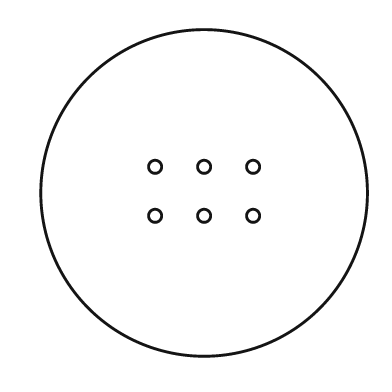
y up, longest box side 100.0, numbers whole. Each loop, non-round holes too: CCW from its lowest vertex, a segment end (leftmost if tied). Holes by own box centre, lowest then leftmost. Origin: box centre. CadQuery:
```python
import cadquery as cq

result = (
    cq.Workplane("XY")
    .moveTo(0.0, 0.0)
    .circle(50.0)
    .moveTo(-15.0, -7.0)
    .circle(2.0)
    .moveTo(0.0, -7.0)
    .circle(2.0)
    .moveTo(15.0, -7.0)
    .circle(2.0)
    .moveTo(-15.0, 8.0)
    .circle(2.0)
    .moveTo(0.0, 8.0)
    .circle(2.0)
    .moveTo(15.0, 8.0)
    .circle(2.0)
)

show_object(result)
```